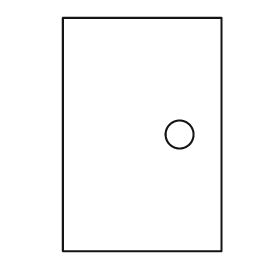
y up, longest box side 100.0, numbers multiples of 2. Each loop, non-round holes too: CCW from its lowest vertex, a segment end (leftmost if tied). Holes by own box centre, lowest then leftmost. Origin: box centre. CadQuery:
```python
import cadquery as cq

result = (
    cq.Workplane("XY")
    .moveTo(-34.0, -50.0)
    .lineTo(34.0, -50.0)
    .lineTo(34.0, 50.0)
    .lineTo(-34.0, 50.0)
    .close()
    .moveTo(16.0, 0.0)
    .circle(6.0)
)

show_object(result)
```